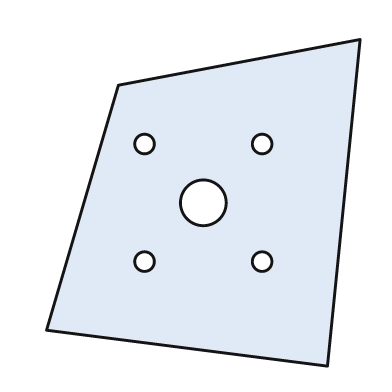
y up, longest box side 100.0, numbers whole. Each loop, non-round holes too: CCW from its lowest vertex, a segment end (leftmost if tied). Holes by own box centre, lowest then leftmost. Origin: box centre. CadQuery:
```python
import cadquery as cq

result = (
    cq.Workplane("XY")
    .moveTo(38.0, -50.0)
    .lineTo(48.0, 50.0)
    .lineTo(-26.0, 36.0)
    .lineTo(-48.0, -39.0)
    .close()
    .moveTo(-18.0, -18.0)
    .circle(3.0)
    .moveTo(18.0, -18.0)
    .circle(3.0)
    .moveTo(0.0, 0.0)
    .circle(7.0)
    .moveTo(-18.0, 18.0)
    .circle(3.0)
    .moveTo(18.0, 18.0)
    .circle(3.0)
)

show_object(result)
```